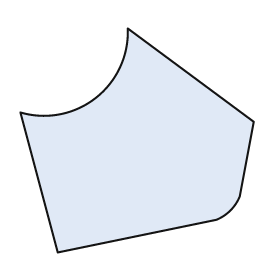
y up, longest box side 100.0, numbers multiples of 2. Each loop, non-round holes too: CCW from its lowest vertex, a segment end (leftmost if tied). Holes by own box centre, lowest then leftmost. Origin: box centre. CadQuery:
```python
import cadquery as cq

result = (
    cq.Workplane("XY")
    .moveTo(-34.0, -48.0)
    .lineTo(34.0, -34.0)
    .threePointArc((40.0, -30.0), (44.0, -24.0))
    .lineTo(50.0, 8.0)
    .lineTo(-4.0, 48.0)
    .threePointArc((-18.0, 18.0), (-50.0, 12.0))
    .close()
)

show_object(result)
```